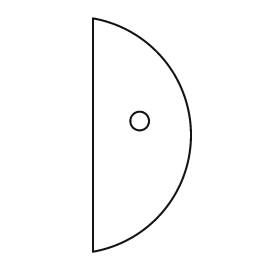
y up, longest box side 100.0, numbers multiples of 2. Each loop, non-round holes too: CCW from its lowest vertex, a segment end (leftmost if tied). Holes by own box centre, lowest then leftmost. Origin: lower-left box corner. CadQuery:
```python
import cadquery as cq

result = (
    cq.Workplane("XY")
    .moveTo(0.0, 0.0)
    .threePointArc((42.0, 50.0), (0.0, 100.0))
    .close()
    .moveTo(20.0, 56.0)
    .circle(4.0)
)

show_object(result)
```